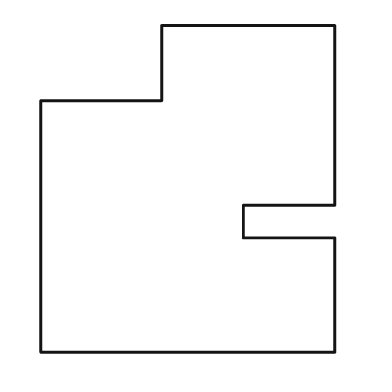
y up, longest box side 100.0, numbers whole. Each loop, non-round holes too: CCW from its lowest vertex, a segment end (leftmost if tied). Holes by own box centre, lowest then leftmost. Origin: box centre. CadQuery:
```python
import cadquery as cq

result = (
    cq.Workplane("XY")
    .moveTo(-45.0, -50.0)
    .lineTo(45.0, -50.0)
    .lineTo(45.0, -15.0)
    .lineTo(17.0, -15.0)
    .lineTo(17.0, -5.0)
    .lineTo(45.0, -5.0)
    .lineTo(45.0, 50.0)
    .lineTo(-8.0, 50.0)
    .lineTo(-8.0, 27.0)
    .lineTo(-45.0, 27.0)
    .close()
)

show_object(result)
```